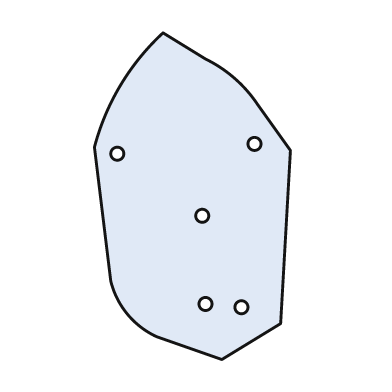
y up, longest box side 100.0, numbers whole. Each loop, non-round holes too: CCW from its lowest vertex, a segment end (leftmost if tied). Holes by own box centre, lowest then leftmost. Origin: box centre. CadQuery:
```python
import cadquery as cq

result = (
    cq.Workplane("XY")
    .moveTo(9.0, -50.0)
    .lineTo(27.0, -39.0)
    .lineTo(30.0, 14.0)
    .lineTo(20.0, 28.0)
    .threePointArc((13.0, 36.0), (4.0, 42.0))
    .lineTo(-9.0, 50.0)
    .threePointArc((-22.0, 34.0), (-30.0, 15.0))
    .lineTo(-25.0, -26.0)
    .threePointArc((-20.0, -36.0), (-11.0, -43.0))
    .close()
    .moveTo(15.0, -34.0)
    .circle(2.0)
    .moveTo(4.0, -33.0)
    .circle(2.0)
    .moveTo(3.0, -6.0)
    .circle(2.0)
    .moveTo(-23.0, 13.0)
    .circle(2.0)
    .moveTo(19.0, 16.0)
    .circle(2.0)
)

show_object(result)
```